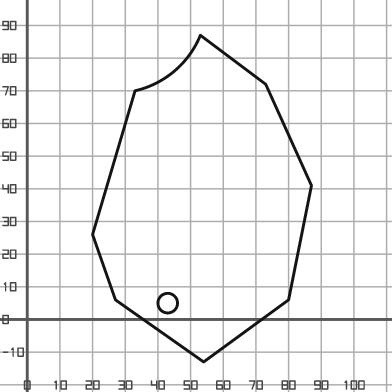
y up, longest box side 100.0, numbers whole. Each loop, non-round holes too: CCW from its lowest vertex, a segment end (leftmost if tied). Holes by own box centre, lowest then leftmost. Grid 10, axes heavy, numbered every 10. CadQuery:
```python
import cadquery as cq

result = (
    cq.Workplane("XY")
    .moveTo(54.0, -13.0)
    .lineTo(80.0, 6.0)
    .lineTo(87.0, 41.0)
    .lineTo(73.0, 72.0)
    .lineTo(53.0, 87.0)
    .threePointArc((45.0, 76.0), (33.0, 70.0))
    .lineTo(20.0, 26.0)
    .lineTo(27.0, 6.0)
    .close()
    .moveTo(43.0, 5.0)
    .circle(3.0)
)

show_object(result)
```